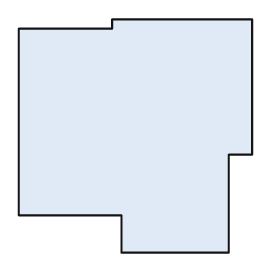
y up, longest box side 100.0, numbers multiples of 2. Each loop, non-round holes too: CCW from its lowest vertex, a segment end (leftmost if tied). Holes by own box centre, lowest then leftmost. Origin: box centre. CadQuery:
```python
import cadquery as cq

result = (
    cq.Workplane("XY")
    .moveTo(-6.0, -50.0)
    .lineTo(40.0, -50.0)
    .lineTo(40.0, -8.0)
    .lineTo(50.0, -8.0)
    .lineTo(50.0, 50.0)
    .lineTo(-10.0, 50.0)
    .lineTo(-10.0, 46.0)
    .lineTo(-50.0, 46.0)
    .lineTo(-50.0, -34.0)
    .lineTo(-6.0, -34.0)
    .close()
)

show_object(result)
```